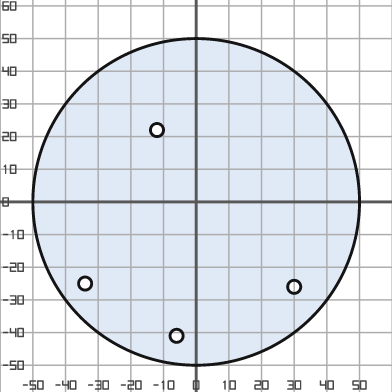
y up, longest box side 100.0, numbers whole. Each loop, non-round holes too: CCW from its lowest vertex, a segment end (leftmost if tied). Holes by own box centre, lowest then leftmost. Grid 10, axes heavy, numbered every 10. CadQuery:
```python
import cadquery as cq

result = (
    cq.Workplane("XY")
    .moveTo(0.0, 0.0)
    .circle(50.0)
    .moveTo(-6.0, -41.0)
    .circle(2.0)
    .moveTo(30.0, -26.0)
    .circle(2.0)
    .moveTo(-34.0, -25.0)
    .circle(2.0)
    .moveTo(-12.0, 22.0)
    .circle(2.0)
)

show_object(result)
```